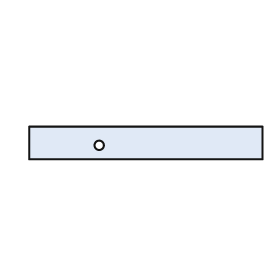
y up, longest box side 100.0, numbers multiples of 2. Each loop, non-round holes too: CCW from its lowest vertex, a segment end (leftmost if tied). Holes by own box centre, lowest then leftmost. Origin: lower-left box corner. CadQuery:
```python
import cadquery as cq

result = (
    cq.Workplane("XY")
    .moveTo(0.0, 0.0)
    .lineTo(100.0, 0.0)
    .lineTo(100.0, 14.0)
    .lineTo(0.0, 14.0)
    .close()
    .moveTo(30.0, 6.0)
    .circle(2.0)
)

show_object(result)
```